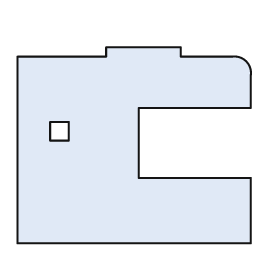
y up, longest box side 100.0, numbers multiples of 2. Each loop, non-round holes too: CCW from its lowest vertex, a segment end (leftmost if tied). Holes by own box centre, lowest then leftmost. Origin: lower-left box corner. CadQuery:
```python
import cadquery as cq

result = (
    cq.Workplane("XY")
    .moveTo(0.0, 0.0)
    .lineTo(100.0, 0.0)
    .lineTo(100.0, 28.0)
    .lineTo(52.0, 28.0)
    .lineTo(52.0, 58.0)
    .lineTo(100.0, 58.0)
    .lineTo(100.0, 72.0)
    .threePointArc((98.0, 78.0), (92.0, 80.0))
    .lineTo(70.0, 80.0)
    .lineTo(70.0, 84.0)
    .lineTo(38.0, 84.0)
    .lineTo(38.0, 80.0)
    .lineTo(0.0, 80.0)
    .close()
    .moveTo(14.0, 44.0)
    .lineTo(22.0, 44.0)
    .lineTo(22.0, 52.0)
    .lineTo(14.0, 52.0)
    .close()
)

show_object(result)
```